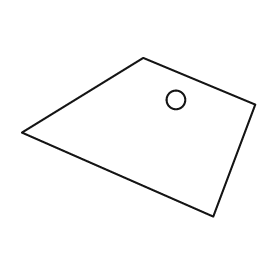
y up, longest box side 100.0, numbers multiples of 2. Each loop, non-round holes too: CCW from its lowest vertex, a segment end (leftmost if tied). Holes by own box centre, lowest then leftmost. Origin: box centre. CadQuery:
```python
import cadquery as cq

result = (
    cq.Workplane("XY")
    .moveTo(32.0, -34.0)
    .lineTo(50.0, 14.0)
    .lineTo(2.0, 34.0)
    .lineTo(-50.0, 2.0)
    .close()
    .moveTo(16.0, 16.0)
    .circle(4.0)
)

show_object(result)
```